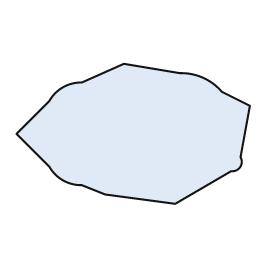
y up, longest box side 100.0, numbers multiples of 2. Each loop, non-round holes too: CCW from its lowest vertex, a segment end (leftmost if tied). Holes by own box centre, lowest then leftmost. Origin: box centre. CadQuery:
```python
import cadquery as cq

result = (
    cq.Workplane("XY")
    .moveTo(18.0, -30.0)
    .lineTo(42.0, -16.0)
    .threePointArc((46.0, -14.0), (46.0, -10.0))
    .lineTo(50.0, 12.0)
    .lineTo(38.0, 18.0)
    .threePointArc((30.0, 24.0), (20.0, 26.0))
    .lineTo(-4.0, 30.0)
    .lineTo(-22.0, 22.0)
    .threePointArc((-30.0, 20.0), (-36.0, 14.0))
    .lineTo(-50.0, 0.0)
    .lineTo(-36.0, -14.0)
    .threePointArc((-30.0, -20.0), (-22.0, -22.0))
    .lineTo(-12.0, -26.0)
    .close()
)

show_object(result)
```